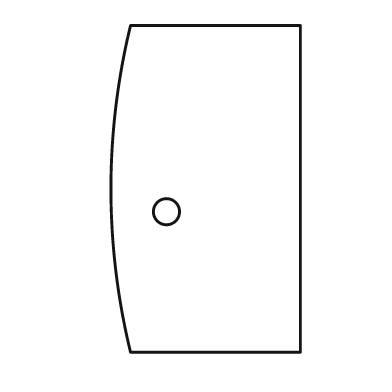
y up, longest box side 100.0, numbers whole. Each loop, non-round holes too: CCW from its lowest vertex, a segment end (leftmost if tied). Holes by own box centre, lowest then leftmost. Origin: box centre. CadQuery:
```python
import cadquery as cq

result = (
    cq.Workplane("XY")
    .moveTo(-23.0, -50.0)
    .lineTo(29.0, -50.0)
    .lineTo(29.0, 50.0)
    .lineTo(-23.0, 50.0)
    .threePointArc((-29.0, 0.0), (-23.0, -50.0))
    .close()
    .moveTo(-12.0, -7.0)
    .circle(4.0)
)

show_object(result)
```